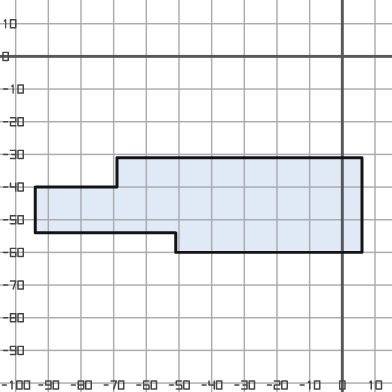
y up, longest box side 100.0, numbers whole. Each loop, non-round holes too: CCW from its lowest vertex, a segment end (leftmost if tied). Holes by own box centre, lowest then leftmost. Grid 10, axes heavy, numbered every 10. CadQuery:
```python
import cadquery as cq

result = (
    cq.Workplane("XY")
    .moveTo(-51.0, -60.0)
    .lineTo(6.0, -60.0)
    .lineTo(6.0, -31.0)
    .lineTo(-69.0, -31.0)
    .lineTo(-69.0, -40.0)
    .lineTo(-94.0, -40.0)
    .lineTo(-94.0, -54.0)
    .lineTo(-51.0, -54.0)
    .close()
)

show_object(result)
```